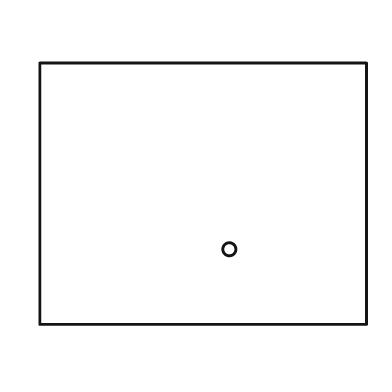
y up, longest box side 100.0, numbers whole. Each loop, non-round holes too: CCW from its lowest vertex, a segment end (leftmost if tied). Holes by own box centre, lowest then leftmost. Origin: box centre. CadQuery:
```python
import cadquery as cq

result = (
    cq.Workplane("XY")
    .moveTo(-50.0, -40.0)
    .lineTo(50.0, -40.0)
    .lineTo(50.0, 40.0)
    .lineTo(-50.0, 40.0)
    .close()
    .moveTo(8.0, -17.0)
    .circle(2.0)
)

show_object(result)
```